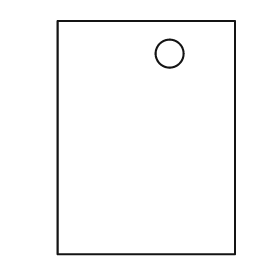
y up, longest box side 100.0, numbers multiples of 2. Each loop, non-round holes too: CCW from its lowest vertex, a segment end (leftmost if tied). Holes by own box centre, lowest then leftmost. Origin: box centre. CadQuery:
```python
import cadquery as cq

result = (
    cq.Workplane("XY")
    .moveTo(-38.0, -50.0)
    .lineTo(38.0, -50.0)
    .lineTo(38.0, 50.0)
    .lineTo(-38.0, 50.0)
    .close()
    .moveTo(10.0, 36.0)
    .circle(6.0)
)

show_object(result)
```